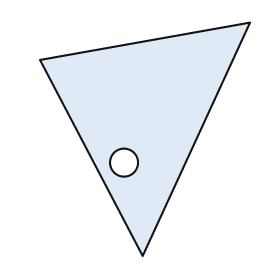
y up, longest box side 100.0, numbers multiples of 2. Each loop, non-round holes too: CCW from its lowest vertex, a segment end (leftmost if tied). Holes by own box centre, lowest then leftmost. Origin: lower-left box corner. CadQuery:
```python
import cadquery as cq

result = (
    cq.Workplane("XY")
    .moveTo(44.0, 0.0)
    .lineTo(90.0, 100.0)
    .lineTo(0.0, 84.0)
    .close()
    .moveTo(36.0, 40.0)
    .circle(6.0)
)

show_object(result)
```